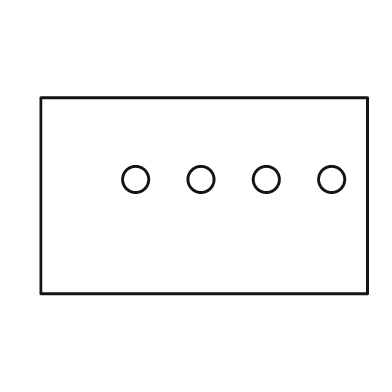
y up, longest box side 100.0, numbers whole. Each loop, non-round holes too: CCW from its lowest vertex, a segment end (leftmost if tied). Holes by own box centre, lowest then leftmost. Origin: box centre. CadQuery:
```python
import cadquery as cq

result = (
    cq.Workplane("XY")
    .moveTo(-50.0, -30.0)
    .lineTo(50.0, -30.0)
    .lineTo(50.0, 30.0)
    .lineTo(-50.0, 30.0)
    .close()
    .moveTo(-21.0, 5.0)
    .circle(4.0)
    .moveTo(-1.0, 5.0)
    .circle(4.0)
    .moveTo(19.0, 5.0)
    .circle(4.0)
    .moveTo(39.0, 5.0)
    .circle(4.0)
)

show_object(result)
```